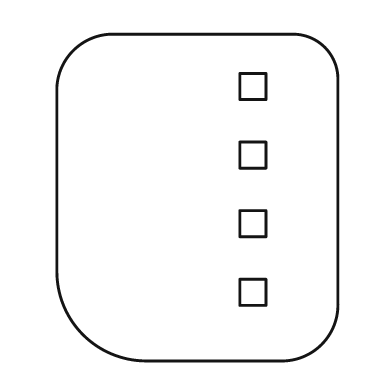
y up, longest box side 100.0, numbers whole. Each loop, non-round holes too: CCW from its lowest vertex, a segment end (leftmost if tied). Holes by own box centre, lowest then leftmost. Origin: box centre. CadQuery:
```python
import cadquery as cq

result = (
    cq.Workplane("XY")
    .moveTo(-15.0, -50.0)
    .lineTo(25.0, -50.0)
    .threePointArc((38.0, -45.0), (43.0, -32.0))
    .lineTo(43.0, 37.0)
    .threePointArc((39.0, 46.0), (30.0, 50.0))
    .lineTo(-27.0, 50.0)
    .threePointArc((-38.0, 45.0), (-43.0, 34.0))
    .lineTo(-43.0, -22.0)
    .threePointArc((-35.0, -42.0), (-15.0, -50.0))
    .close()
    .moveTo(13.0, -33.0)
    .lineTo(21.0, -33.0)
    .lineTo(21.0, -25.0)
    .lineTo(13.0, -25.0)
    .close()
    .moveTo(13.0, -12.0)
    .lineTo(21.0, -12.0)
    .lineTo(21.0, -4.0)
    .lineTo(13.0, -4.0)
    .close()
    .moveTo(13.0, 9.0)
    .lineTo(21.0, 9.0)
    .lineTo(21.0, 17.0)
    .lineTo(13.0, 17.0)
    .close()
    .moveTo(13.0, 30.0)
    .lineTo(21.0, 30.0)
    .lineTo(21.0, 38.0)
    .lineTo(13.0, 38.0)
    .close()
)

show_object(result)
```